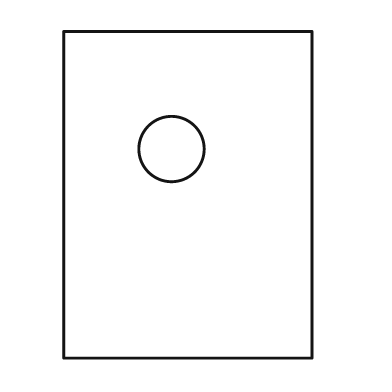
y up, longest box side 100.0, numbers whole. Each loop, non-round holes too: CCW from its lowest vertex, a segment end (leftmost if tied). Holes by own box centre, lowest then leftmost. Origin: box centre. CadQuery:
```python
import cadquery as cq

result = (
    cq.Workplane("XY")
    .moveTo(-38.0, -50.0)
    .lineTo(38.0, -50.0)
    .lineTo(38.0, 50.0)
    .lineTo(-38.0, 50.0)
    .close()
    .moveTo(-5.0, 14.0)
    .circle(10.0)
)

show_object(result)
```